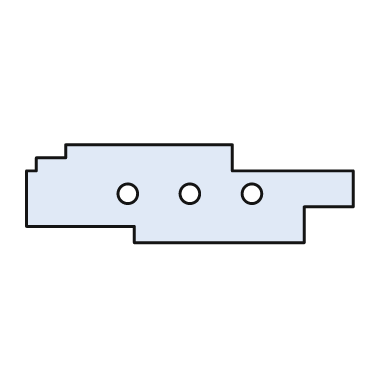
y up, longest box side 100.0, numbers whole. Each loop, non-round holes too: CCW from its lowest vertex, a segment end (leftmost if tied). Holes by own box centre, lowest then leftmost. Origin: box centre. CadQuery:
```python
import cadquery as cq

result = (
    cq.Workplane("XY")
    .moveTo(-17.0, -15.0)
    .lineTo(35.0, -15.0)
    .lineTo(35.0, -4.0)
    .lineTo(50.0, -4.0)
    .lineTo(50.0, 7.0)
    .lineTo(13.0, 7.0)
    .lineTo(13.0, 15.0)
    .lineTo(-38.0, 15.0)
    .lineTo(-38.0, 11.0)
    .lineTo(-47.0, 11.0)
    .lineTo(-47.0, 7.0)
    .lineTo(-50.0, 7.0)
    .lineTo(-50.0, -10.0)
    .lineTo(-17.0, -10.0)
    .close()
    .moveTo(-19.0, 0.0)
    .circle(3.0)
    .moveTo(0.0, 0.0)
    .circle(3.0)
    .moveTo(19.0, 0.0)
    .circle(3.0)
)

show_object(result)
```